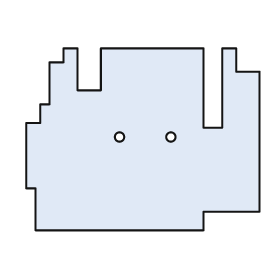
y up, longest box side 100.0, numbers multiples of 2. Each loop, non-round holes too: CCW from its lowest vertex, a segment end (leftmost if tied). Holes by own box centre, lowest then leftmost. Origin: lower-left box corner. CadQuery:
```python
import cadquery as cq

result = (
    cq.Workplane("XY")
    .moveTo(4.0, 0.0)
    .lineTo(76.0, 0.0)
    .lineTo(76.0, 8.0)
    .lineTo(100.0, 8.0)
    .lineTo(100.0, 68.0)
    .lineTo(90.0, 68.0)
    .lineTo(90.0, 78.0)
    .lineTo(84.0, 78.0)
    .lineTo(84.0, 44.0)
    .lineTo(76.0, 44.0)
    .lineTo(76.0, 78.0)
    .lineTo(32.0, 78.0)
    .lineTo(32.0, 60.0)
    .lineTo(22.0, 60.0)
    .lineTo(22.0, 78.0)
    .lineTo(16.0, 78.0)
    .lineTo(16.0, 72.0)
    .lineTo(10.0, 72.0)
    .lineTo(10.0, 54.0)
    .lineTo(6.0, 54.0)
    .lineTo(6.0, 46.0)
    .lineTo(0.0, 46.0)
    .lineTo(0.0, 18.0)
    .lineTo(4.0, 18.0)
    .close()
    .moveTo(40.0, 40.0)
    .circle(2.0)
    .moveTo(62.0, 40.0)
    .circle(2.0)
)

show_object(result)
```